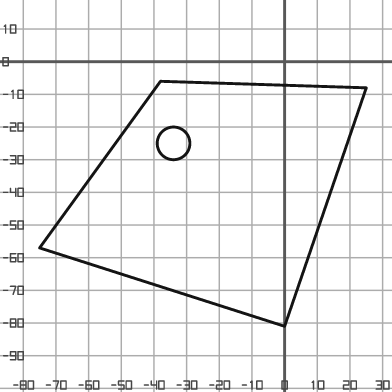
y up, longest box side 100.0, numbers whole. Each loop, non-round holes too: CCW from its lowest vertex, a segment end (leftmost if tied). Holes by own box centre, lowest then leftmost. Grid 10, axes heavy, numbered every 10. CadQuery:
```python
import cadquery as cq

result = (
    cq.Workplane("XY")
    .moveTo(0.0, -81.0)
    .lineTo(25.0, -8.0)
    .lineTo(-38.0, -6.0)
    .lineTo(-75.0, -57.0)
    .close()
    .moveTo(-34.0, -25.0)
    .circle(5.0)
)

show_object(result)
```